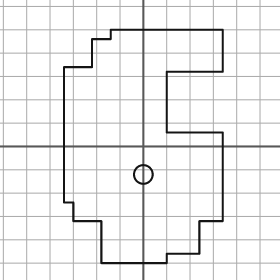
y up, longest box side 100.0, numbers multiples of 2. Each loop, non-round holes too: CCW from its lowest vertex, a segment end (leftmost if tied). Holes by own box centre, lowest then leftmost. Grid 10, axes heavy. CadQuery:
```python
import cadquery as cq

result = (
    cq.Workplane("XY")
    .moveTo(-18.0, -50.0)
    .lineTo(10.0, -50.0)
    .lineTo(10.0, -46.0)
    .lineTo(24.0, -46.0)
    .lineTo(24.0, -32.0)
    .lineTo(34.0, -32.0)
    .lineTo(34.0, 6.0)
    .lineTo(10.0, 6.0)
    .lineTo(10.0, 32.0)
    .lineTo(34.0, 32.0)
    .lineTo(34.0, 50.0)
    .lineTo(-14.0, 50.0)
    .lineTo(-14.0, 46.0)
    .lineTo(-22.0, 46.0)
    .lineTo(-22.0, 34.0)
    .lineTo(-34.0, 34.0)
    .lineTo(-34.0, -24.0)
    .lineTo(-30.0, -24.0)
    .lineTo(-30.0, -32.0)
    .lineTo(-18.0, -32.0)
    .close()
    .moveTo(0.0, -12.0)
    .circle(4.0)
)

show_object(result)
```